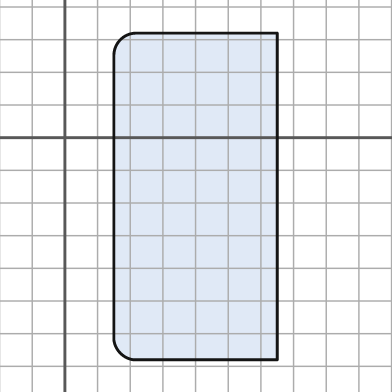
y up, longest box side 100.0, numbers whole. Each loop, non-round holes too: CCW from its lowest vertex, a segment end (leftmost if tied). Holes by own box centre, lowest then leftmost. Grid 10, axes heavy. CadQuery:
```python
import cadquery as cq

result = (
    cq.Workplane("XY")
    .moveTo(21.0, -68.0)
    .lineTo(65.0, -68.0)
    .lineTo(65.0, 32.0)
    .lineTo(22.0, 32.0)
    .threePointArc((17.0, 30.0), (15.0, 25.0))
    .lineTo(15.0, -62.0)
    .threePointArc((17.0, -66.0), (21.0, -68.0))
    .close()
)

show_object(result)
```